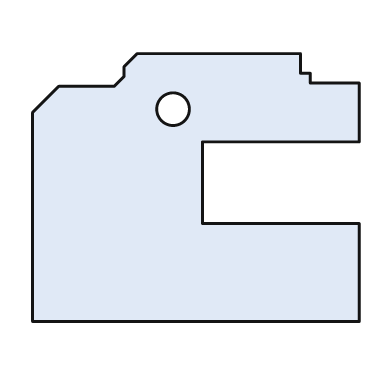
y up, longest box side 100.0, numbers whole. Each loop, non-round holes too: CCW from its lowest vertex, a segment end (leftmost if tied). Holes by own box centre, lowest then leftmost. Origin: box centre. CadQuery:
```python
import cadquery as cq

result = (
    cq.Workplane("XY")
    .moveTo(-50.0, -41.0)
    .lineTo(50.0, -41.0)
    .lineTo(50.0, -11.0)
    .lineTo(2.0, -11.0)
    .lineTo(2.0, 14.0)
    .lineTo(50.0, 14.0)
    .lineTo(50.0, 32.0)
    .lineTo(35.0, 32.0)
    .lineTo(35.0, 35.0)
    .lineTo(32.0, 35.0)
    .lineTo(32.0, 41.0)
    .lineTo(-18.0, 41.0)
    .lineTo(-22.0, 37.0)
    .lineTo(-22.0, 34.0)
    .lineTo(-25.0, 31.0)
    .lineTo(-42.0, 31.0)
    .lineTo(-50.0, 23.0)
    .close()
    .moveTo(-7.0, 24.0)
    .circle(5.0)
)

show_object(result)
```